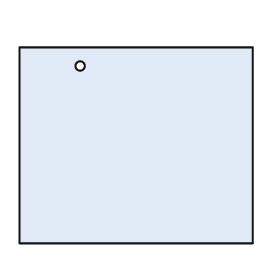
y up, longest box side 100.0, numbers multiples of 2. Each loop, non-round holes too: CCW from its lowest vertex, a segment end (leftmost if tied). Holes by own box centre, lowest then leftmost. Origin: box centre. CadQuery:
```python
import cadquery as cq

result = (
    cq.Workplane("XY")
    .moveTo(-50.0, -42.0)
    .lineTo(50.0, -42.0)
    .lineTo(50.0, 42.0)
    .lineTo(-50.0, 42.0)
    .close()
    .moveTo(-24.0, 34.0)
    .circle(2.0)
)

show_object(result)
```